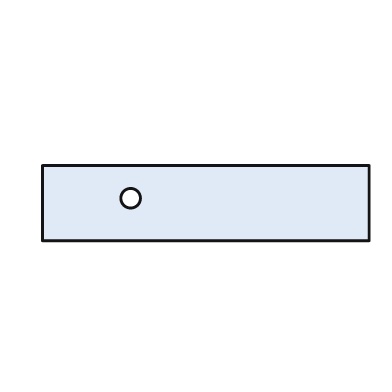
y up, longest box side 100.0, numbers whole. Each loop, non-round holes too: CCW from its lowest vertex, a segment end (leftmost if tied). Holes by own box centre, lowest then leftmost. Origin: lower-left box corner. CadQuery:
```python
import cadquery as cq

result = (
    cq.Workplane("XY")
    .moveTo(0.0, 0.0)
    .lineTo(100.0, 0.0)
    .lineTo(100.0, 23.0)
    .lineTo(0.0, 23.0)
    .close()
    .moveTo(27.0, 13.0)
    .circle(3.0)
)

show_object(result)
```